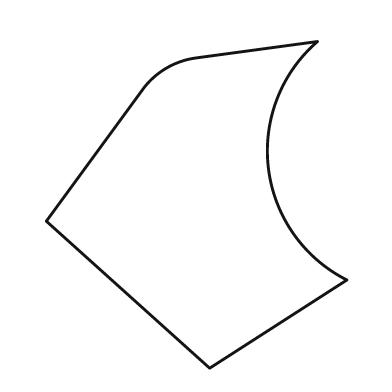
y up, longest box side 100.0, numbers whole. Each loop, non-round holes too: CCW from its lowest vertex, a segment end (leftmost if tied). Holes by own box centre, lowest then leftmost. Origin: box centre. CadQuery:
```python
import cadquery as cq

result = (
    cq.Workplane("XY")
    .moveTo(4.0, -50.0)
    .lineTo(46.0, -23.0)
    .threePointArc((22.0, 11.0), (37.0, 50.0))
    .lineTo(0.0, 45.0)
    .threePointArc((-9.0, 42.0), (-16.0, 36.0))
    .lineTo(-46.0, -5.0)
    .close()
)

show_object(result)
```